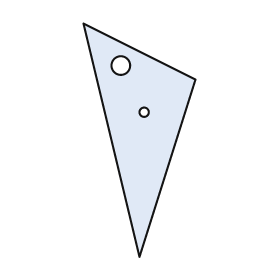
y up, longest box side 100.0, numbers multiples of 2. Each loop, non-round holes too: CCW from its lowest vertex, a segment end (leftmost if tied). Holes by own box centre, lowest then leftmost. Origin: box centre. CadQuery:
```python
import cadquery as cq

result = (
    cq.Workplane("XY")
    .moveTo(0.0, -50.0)
    .lineTo(24.0, 26.0)
    .lineTo(-24.0, 50.0)
    .close()
    .moveTo(2.0, 12.0)
    .circle(2.0)
    .moveTo(-8.0, 32.0)
    .circle(4.0)
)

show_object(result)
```